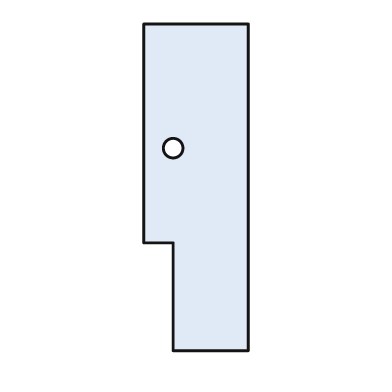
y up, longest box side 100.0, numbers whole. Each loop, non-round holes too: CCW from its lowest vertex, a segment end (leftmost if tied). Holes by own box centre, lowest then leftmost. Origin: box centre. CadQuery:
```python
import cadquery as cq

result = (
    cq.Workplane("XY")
    .moveTo(-7.0, -50.0)
    .lineTo(16.0, -50.0)
    .lineTo(16.0, 50.0)
    .lineTo(-16.0, 50.0)
    .lineTo(-16.0, -17.0)
    .lineTo(-7.0, -17.0)
    .close()
    .moveTo(-7.0, 12.0)
    .circle(3.0)
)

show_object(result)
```